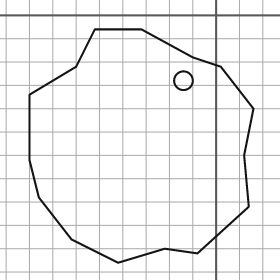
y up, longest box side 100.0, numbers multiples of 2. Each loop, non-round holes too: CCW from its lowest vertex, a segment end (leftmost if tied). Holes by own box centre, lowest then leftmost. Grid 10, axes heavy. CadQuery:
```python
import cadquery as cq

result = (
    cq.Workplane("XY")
    .moveTo(-42.0, -106.0)
    .lineTo(-22.0, -100.0)
    .lineTo(-8.0, -102.0)
    .lineTo(14.0, -82.0)
    .lineTo(12.0, -60.0)
    .lineTo(16.0, -40.0)
    .lineTo(2.0, -22.0)
    .lineTo(-10.0, -18.0)
    .lineTo(-32.0, -6.0)
    .lineTo(-52.0, -6.0)
    .lineTo(-60.0, -22.0)
    .lineTo(-80.0, -34.0)
    .lineTo(-80.0, -62.0)
    .lineTo(-76.0, -78.0)
    .lineTo(-62.0, -96.0)
    .close()
    .moveTo(-14.0, -28.0)
    .circle(4.0)
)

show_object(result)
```